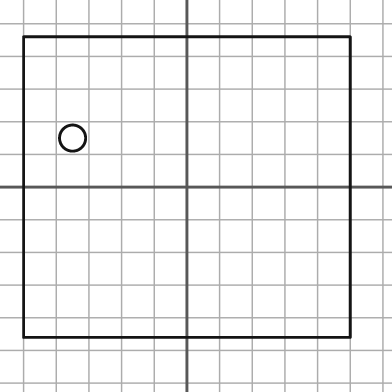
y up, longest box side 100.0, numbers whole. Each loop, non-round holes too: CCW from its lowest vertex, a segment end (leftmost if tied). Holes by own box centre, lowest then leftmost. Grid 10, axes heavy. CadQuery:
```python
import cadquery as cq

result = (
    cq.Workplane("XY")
    .moveTo(-50.0, -46.0)
    .lineTo(50.0, -46.0)
    .lineTo(50.0, 46.0)
    .lineTo(-50.0, 46.0)
    .close()
    .moveTo(-35.0, 15.0)
    .circle(4.0)
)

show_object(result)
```